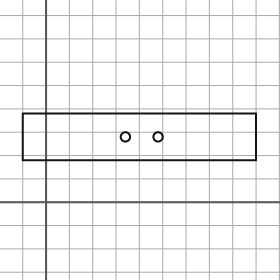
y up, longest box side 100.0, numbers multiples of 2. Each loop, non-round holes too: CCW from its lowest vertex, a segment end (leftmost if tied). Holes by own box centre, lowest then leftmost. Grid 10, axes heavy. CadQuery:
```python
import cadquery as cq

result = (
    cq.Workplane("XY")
    .moveTo(-10.0, 18.0)
    .lineTo(90.0, 18.0)
    .lineTo(90.0, 38.0)
    .lineTo(-10.0, 38.0)
    .close()
    .moveTo(34.0, 28.0)
    .circle(2.0)
    .moveTo(48.0, 28.0)
    .circle(2.0)
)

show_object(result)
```